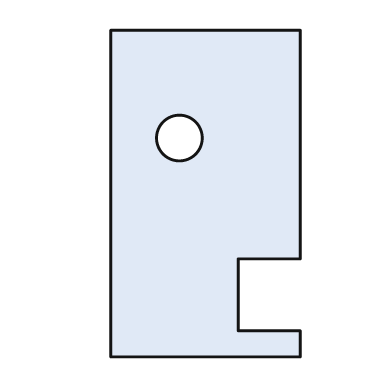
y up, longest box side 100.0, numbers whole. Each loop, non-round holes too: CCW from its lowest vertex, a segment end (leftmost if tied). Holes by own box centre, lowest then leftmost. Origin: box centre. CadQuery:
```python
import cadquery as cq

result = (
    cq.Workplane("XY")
    .moveTo(-29.0, -50.0)
    .lineTo(29.0, -50.0)
    .lineTo(29.0, -42.0)
    .lineTo(10.0, -42.0)
    .lineTo(10.0, -20.0)
    .lineTo(29.0, -20.0)
    .lineTo(29.0, 50.0)
    .lineTo(-29.0, 50.0)
    .close()
    .moveTo(-8.0, 17.0)
    .circle(7.0)
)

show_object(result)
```